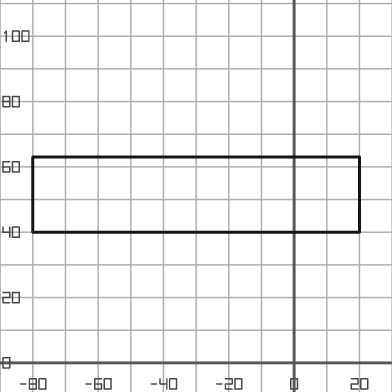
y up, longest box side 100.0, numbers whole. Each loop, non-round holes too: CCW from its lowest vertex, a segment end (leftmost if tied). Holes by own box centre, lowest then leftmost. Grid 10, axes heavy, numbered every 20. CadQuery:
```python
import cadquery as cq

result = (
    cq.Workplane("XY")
    .moveTo(-80.0, 40.0)
    .lineTo(20.0, 40.0)
    .lineTo(20.0, 63.0)
    .lineTo(-80.0, 63.0)
    .close()
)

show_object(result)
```